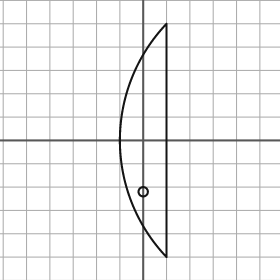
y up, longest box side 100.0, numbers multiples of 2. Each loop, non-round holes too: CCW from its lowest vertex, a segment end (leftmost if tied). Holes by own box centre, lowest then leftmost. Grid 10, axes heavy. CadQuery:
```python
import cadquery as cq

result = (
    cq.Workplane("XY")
    .moveTo(10.0, -50.0)
    .lineTo(10.0, 50.0)
    .threePointArc((-10.0, 0.0), (10.0, -50.0))
    .close()
    .moveTo(0.0, -22.0)
    .circle(2.0)
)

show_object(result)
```